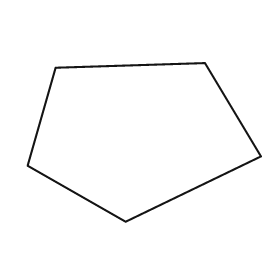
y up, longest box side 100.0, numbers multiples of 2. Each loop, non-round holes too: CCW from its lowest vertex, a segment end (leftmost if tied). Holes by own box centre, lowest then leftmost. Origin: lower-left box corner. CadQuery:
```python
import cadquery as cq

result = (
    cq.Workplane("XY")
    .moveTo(42.0, 0.0)
    .lineTo(100.0, 28.0)
    .lineTo(76.0, 68.0)
    .lineTo(12.0, 66.0)
    .lineTo(0.0, 24.0)
    .close()
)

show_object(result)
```